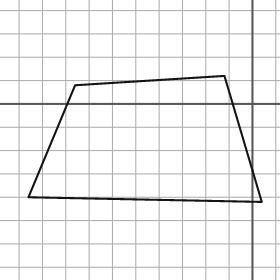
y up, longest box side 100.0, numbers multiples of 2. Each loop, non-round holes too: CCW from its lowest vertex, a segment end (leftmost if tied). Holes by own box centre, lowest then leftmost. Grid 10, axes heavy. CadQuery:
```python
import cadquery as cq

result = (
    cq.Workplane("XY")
    .moveTo(4.0, -42.0)
    .lineTo(-12.0, 12.0)
    .lineTo(-76.0, 8.0)
    .lineTo(-96.0, -40.0)
    .close()
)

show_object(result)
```